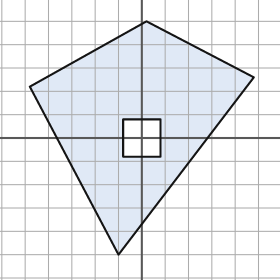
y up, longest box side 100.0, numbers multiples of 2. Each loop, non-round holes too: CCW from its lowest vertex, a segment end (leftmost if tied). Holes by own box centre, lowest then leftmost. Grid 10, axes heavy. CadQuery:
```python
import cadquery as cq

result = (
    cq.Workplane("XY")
    .moveTo(-10.0, -50.0)
    .lineTo(48.0, 26.0)
    .lineTo(2.0, 50.0)
    .lineTo(-48.0, 22.0)
    .close()
    .moveTo(-8.0, -8.0)
    .lineTo(8.0, -8.0)
    .lineTo(8.0, 8.0)
    .lineTo(-8.0, 8.0)
    .close()
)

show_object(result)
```